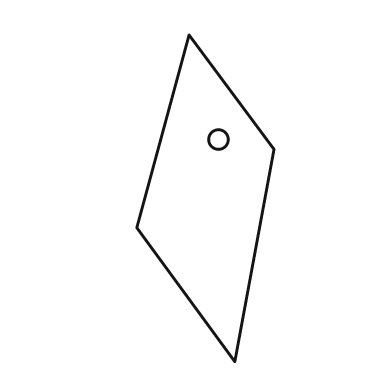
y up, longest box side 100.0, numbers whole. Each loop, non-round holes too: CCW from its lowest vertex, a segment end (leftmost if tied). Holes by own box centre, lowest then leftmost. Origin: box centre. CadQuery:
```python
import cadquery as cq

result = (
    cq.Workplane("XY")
    .moveTo(9.0, -50.0)
    .lineTo(21.0, 15.0)
    .lineTo(-5.0, 50.0)
    .lineTo(-21.0, -9.0)
    .close()
    .moveTo(4.0, 18.0)
    .circle(3.0)
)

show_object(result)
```